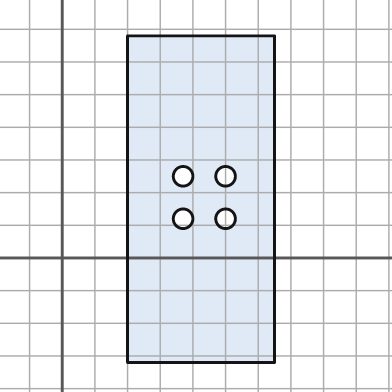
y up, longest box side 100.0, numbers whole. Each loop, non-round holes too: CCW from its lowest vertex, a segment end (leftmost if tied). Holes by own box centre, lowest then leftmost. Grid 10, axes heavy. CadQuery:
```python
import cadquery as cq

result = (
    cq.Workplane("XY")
    .moveTo(20.0, -32.0)
    .lineTo(65.0, -32.0)
    .lineTo(65.0, 68.0)
    .lineTo(20.0, 68.0)
    .close()
    .moveTo(37.0, 12.0)
    .circle(3.0)
    .moveTo(50.0, 12.0)
    .circle(3.0)
    .moveTo(37.0, 25.0)
    .circle(3.0)
    .moveTo(50.0, 25.0)
    .circle(3.0)
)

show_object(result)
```